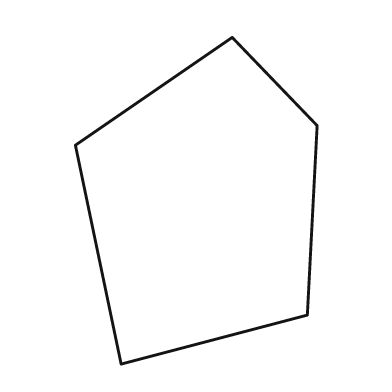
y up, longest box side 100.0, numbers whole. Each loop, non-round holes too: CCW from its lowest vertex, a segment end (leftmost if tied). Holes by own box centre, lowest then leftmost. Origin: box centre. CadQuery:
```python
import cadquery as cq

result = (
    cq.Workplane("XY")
    .moveTo(-23.0, -50.0)
    .lineTo(34.0, -35.0)
    .lineTo(37.0, 23.0)
    .lineTo(11.0, 50.0)
    .lineTo(-37.0, 17.0)
    .close()
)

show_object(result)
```